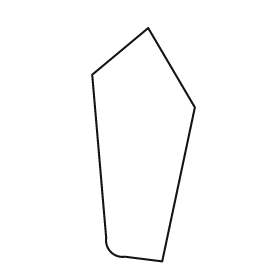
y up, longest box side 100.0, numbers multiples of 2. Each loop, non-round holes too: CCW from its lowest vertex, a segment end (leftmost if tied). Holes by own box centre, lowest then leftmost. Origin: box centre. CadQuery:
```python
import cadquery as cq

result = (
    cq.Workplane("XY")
    .moveTo(8.0, -50.0)
    .lineTo(22.0, 16.0)
    .lineTo(2.0, 50.0)
    .lineTo(-22.0, 30.0)
    .lineTo(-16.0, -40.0)
    .threePointArc((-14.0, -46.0), (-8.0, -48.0))
    .close()
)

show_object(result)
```